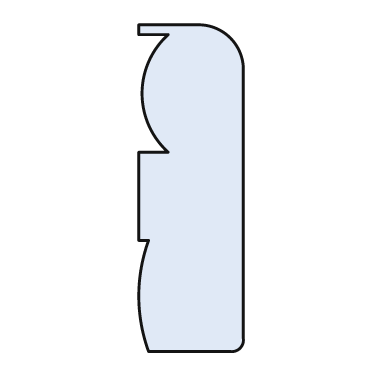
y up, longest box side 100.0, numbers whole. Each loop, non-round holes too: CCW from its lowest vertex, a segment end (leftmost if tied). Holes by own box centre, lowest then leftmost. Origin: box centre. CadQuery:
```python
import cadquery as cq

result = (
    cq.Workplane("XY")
    .moveTo(-13.0, -50.0)
    .lineTo(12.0, -50.0)
    .threePointArc((15.0, -49.0), (16.0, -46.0))
    .lineTo(16.0, 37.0)
    .threePointArc((12.0, 46.0), (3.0, 50.0))
    .lineTo(-16.0, 50.0)
    .lineTo(-16.0, 47.0)
    .lineTo(-7.0, 47.0)
    .threePointArc((-15.0, 29.0), (-7.0, 11.0))
    .lineTo(-16.0, 11.0)
    .lineTo(-16.0, -16.0)
    .lineTo(-13.0, -16.0)
    .threePointArc((-16.0, -33.0), (-13.0, -50.0))
    .close()
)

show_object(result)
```